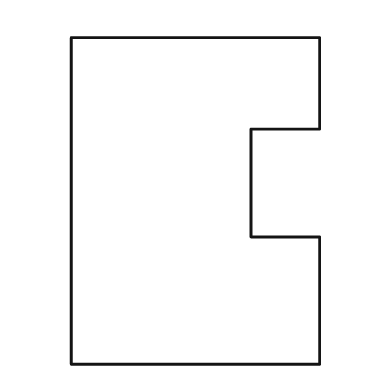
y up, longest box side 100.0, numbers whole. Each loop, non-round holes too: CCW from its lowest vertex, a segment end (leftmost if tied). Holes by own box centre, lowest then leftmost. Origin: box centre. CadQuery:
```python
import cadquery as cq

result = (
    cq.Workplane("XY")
    .moveTo(-38.0, -50.0)
    .lineTo(38.0, -50.0)
    .lineTo(38.0, -11.0)
    .lineTo(17.0, -11.0)
    .lineTo(17.0, 22.0)
    .lineTo(38.0, 22.0)
    .lineTo(38.0, 50.0)
    .lineTo(-38.0, 50.0)
    .close()
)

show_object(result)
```